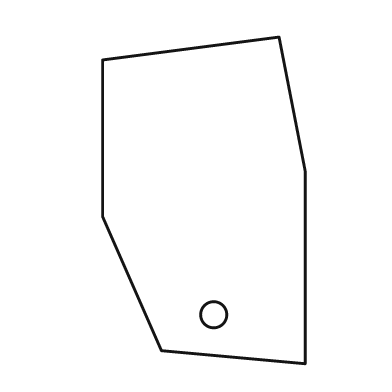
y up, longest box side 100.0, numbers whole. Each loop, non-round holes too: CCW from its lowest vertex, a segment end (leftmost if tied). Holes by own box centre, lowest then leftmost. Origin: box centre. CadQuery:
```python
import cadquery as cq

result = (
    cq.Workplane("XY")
    .moveTo(31.0, -50.0)
    .lineTo(31.0, 9.0)
    .lineTo(23.0, 50.0)
    .lineTo(-31.0, 43.0)
    .lineTo(-31.0, -5.0)
    .lineTo(-13.0, -46.0)
    .close()
    .moveTo(3.0, -35.0)
    .circle(4.0)
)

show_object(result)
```